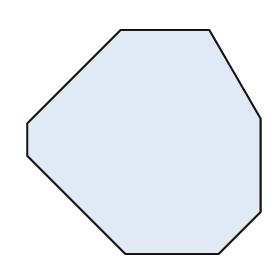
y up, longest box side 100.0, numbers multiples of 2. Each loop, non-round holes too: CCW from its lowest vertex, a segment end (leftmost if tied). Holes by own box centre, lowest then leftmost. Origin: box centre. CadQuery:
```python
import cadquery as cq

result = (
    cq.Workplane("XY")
    .moveTo(-8.0, -48.0)
    .lineTo(32.0, -48.0)
    .lineTo(50.0, -30.0)
    .lineTo(50.0, 10.0)
    .lineTo(28.0, 48.0)
    .lineTo(-10.0, 48.0)
    .lineTo(-50.0, 8.0)
    .lineTo(-50.0, -6.0)
    .close()
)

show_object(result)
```